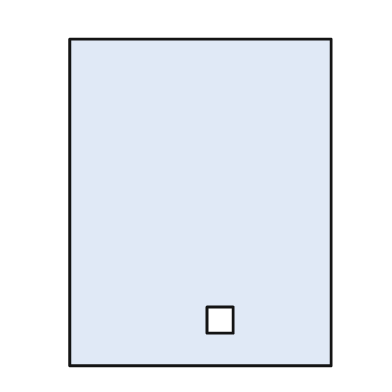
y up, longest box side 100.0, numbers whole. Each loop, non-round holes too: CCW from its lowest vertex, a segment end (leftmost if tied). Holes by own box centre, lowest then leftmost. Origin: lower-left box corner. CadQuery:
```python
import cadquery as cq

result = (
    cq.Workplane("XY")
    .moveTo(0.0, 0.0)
    .lineTo(80.0, 0.0)
    .lineTo(80.0, 100.0)
    .lineTo(0.0, 100.0)
    .close()
    .moveTo(42.0, 10.0)
    .lineTo(50.0, 10.0)
    .lineTo(50.0, 18.0)
    .lineTo(42.0, 18.0)
    .close()
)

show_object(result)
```